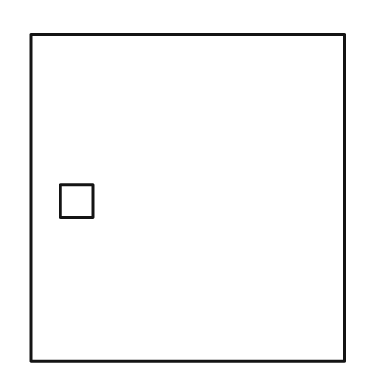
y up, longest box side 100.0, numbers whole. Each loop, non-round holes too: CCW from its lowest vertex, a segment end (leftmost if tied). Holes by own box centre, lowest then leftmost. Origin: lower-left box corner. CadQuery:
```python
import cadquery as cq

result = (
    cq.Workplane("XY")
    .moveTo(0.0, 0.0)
    .lineTo(96.0, 0.0)
    .lineTo(96.0, 100.0)
    .lineTo(0.0, 100.0)
    .close()
    .moveTo(9.0, 44.0)
    .lineTo(19.0, 44.0)
    .lineTo(19.0, 54.0)
    .lineTo(9.0, 54.0)
    .close()
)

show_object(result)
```